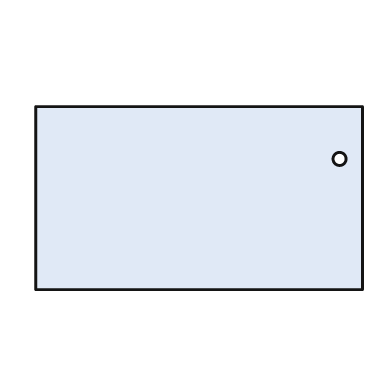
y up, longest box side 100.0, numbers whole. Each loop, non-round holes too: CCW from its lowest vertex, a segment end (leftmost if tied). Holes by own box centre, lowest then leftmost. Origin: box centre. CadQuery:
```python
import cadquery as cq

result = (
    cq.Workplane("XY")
    .moveTo(-50.0, -28.0)
    .lineTo(50.0, -28.0)
    .lineTo(50.0, 28.0)
    .lineTo(-50.0, 28.0)
    .close()
    .moveTo(43.0, 12.0)
    .circle(2.0)
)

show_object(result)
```